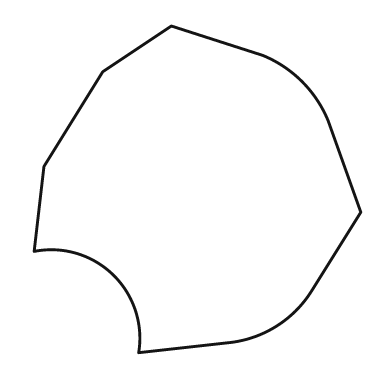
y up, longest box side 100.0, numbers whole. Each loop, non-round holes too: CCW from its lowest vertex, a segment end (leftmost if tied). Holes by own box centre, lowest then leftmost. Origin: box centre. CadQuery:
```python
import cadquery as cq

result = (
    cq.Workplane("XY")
    .moveTo(-18.0, -50.0)
    .lineTo(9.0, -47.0)
    .threePointArc((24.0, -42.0), (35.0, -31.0))
    .lineTo(50.0, -7.0)
    .lineTo(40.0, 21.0)
    .threePointArc((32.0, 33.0), (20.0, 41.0))
    .lineTo(-8.0, 50.0)
    .lineTo(-29.0, 36.0)
    .lineTo(-47.0, 7.0)
    .lineTo(-50.0, -19.0)
    .threePointArc((-26.0, -26.0), (-18.0, -50.0))
    .close()
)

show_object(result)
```